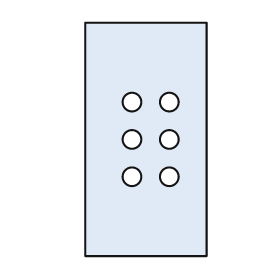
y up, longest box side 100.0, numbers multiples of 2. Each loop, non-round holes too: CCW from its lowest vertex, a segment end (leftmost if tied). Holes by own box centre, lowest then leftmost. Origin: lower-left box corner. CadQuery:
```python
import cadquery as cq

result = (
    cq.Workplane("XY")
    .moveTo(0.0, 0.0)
    .lineTo(52.0, 0.0)
    .lineTo(52.0, 100.0)
    .lineTo(0.0, 100.0)
    .close()
    .moveTo(20.0, 34.0)
    .circle(4.0)
    .moveTo(36.0, 34.0)
    .circle(4.0)
    .moveTo(20.0, 50.0)
    .circle(4.0)
    .moveTo(36.0, 50.0)
    .circle(4.0)
    .moveTo(20.0, 66.0)
    .circle(4.0)
    .moveTo(36.0, 66.0)
    .circle(4.0)
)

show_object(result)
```